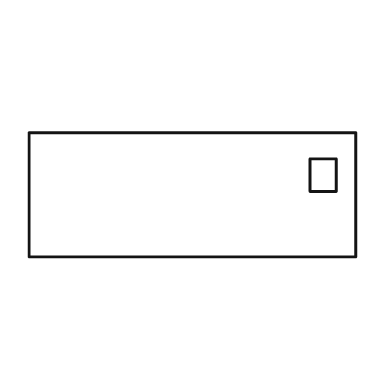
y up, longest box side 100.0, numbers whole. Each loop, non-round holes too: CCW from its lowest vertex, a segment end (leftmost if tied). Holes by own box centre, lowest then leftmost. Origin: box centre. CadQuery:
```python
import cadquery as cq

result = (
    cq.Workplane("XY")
    .moveTo(-50.0, -19.0)
    .lineTo(50.0, -19.0)
    .lineTo(50.0, 19.0)
    .lineTo(-50.0, 19.0)
    .close()
    .moveTo(36.0, 1.0)
    .lineTo(44.0, 1.0)
    .lineTo(44.0, 11.0)
    .lineTo(36.0, 11.0)
    .close()
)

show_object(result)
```